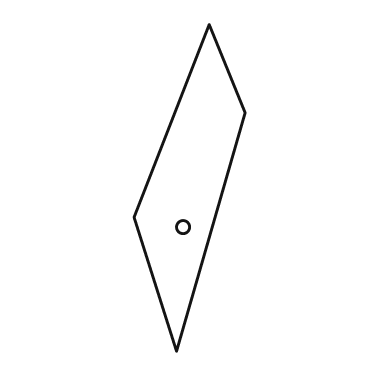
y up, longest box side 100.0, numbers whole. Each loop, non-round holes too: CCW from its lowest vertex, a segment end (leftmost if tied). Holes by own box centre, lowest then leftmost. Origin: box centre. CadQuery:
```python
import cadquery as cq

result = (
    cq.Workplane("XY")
    .moveTo(-4.0, -50.0)
    .lineTo(17.0, 23.0)
    .lineTo(6.0, 50.0)
    .lineTo(-17.0, -9.0)
    .close()
    .moveTo(-2.0, -12.0)
    .circle(2.0)
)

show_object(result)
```